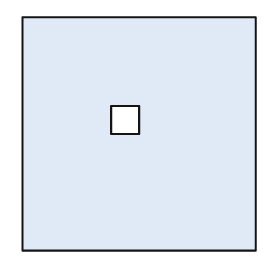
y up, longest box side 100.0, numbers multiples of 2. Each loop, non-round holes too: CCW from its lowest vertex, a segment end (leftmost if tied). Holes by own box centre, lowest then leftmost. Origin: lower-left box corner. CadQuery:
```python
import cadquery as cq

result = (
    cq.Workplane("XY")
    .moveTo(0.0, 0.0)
    .lineTo(100.0, 0.0)
    .lineTo(100.0, 100.0)
    .lineTo(0.0, 100.0)
    .close()
    .moveTo(38.0, 50.0)
    .lineTo(50.0, 50.0)
    .lineTo(50.0, 62.0)
    .lineTo(38.0, 62.0)
    .close()
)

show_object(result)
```